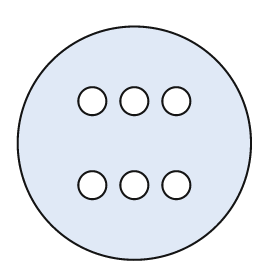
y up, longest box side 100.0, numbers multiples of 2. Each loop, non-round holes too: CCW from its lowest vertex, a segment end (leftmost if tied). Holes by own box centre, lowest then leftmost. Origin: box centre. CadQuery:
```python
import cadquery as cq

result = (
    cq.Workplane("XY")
    .moveTo(0.0, 0.0)
    .circle(50.0)
    .moveTo(-18.0, -18.0)
    .circle(6.0)
    .moveTo(0.0, -18.0)
    .circle(6.0)
    .moveTo(18.0, -18.0)
    .circle(6.0)
    .moveTo(-18.0, 18.0)
    .circle(6.0)
    .moveTo(0.0, 18.0)
    .circle(6.0)
    .moveTo(18.0, 18.0)
    .circle(6.0)
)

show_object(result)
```